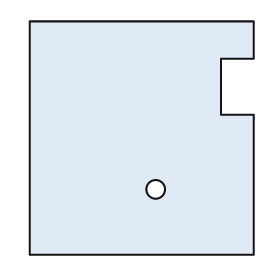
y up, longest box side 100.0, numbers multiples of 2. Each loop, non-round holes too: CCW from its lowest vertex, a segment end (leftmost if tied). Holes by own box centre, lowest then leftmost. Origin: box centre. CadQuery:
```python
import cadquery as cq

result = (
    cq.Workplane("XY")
    .moveTo(-48.0, -50.0)
    .lineTo(48.0, -50.0)
    .lineTo(48.0, 10.0)
    .lineTo(34.0, 10.0)
    .lineTo(34.0, 34.0)
    .lineTo(48.0, 34.0)
    .lineTo(48.0, 50.0)
    .lineTo(-48.0, 50.0)
    .close()
    .moveTo(6.0, -22.0)
    .circle(4.0)
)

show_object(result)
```